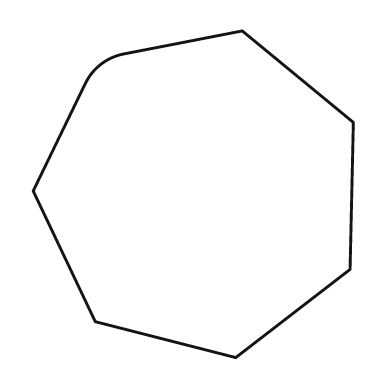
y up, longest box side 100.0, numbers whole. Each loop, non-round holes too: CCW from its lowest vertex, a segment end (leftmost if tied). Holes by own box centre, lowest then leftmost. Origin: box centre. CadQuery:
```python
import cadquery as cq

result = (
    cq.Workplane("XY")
    .moveTo(13.0, -50.0)
    .lineTo(48.0, -23.0)
    .lineTo(49.0, 22.0)
    .lineTo(15.0, 50.0)
    .lineTo(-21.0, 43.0)
    .threePointArc((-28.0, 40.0), (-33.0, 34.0))
    .lineTo(-49.0, 1.0)
    .lineTo(-30.0, -39.0)
    .close()
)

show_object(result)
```